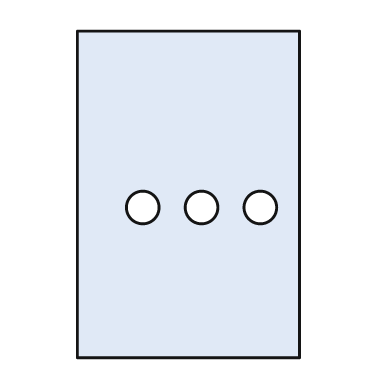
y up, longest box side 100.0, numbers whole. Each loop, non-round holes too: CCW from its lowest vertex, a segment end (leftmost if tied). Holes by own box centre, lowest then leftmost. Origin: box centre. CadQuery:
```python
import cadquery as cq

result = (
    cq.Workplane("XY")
    .moveTo(-34.0, -50.0)
    .lineTo(34.0, -50.0)
    .lineTo(34.0, 50.0)
    .lineTo(-34.0, 50.0)
    .close()
    .moveTo(-14.0, -4.0)
    .circle(5.0)
    .moveTo(4.0, -4.0)
    .circle(5.0)
    .moveTo(22.0, -4.0)
    .circle(5.0)
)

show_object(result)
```